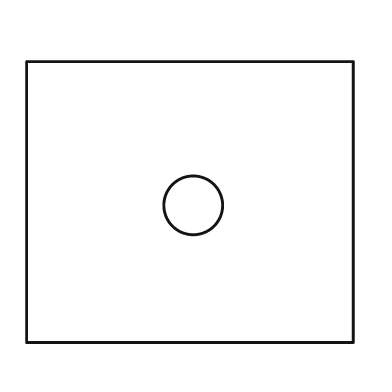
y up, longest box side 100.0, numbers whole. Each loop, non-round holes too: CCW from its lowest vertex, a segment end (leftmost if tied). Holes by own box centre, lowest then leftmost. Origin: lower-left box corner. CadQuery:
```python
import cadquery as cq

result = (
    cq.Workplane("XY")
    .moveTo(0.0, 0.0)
    .lineTo(100.0, 0.0)
    .lineTo(100.0, 86.0)
    .lineTo(0.0, 86.0)
    .close()
    .moveTo(51.0, 42.0)
    .circle(9.0)
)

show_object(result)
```